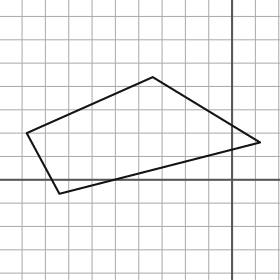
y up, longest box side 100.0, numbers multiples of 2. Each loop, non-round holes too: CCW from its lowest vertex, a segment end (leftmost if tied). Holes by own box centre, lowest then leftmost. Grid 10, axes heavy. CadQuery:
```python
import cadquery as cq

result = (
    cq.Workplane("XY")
    .moveTo(-74.0, -6.0)
    .lineTo(12.0, 16.0)
    .lineTo(-34.0, 44.0)
    .lineTo(-88.0, 20.0)
    .close()
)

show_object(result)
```